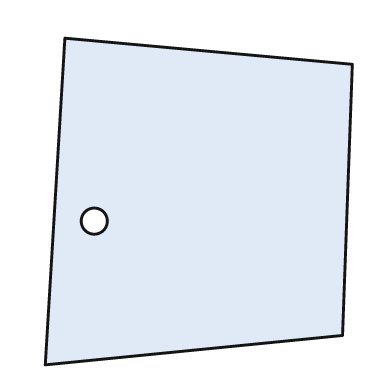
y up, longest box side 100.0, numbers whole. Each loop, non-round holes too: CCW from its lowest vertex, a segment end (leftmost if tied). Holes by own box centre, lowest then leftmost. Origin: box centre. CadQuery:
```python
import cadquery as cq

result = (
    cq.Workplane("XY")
    .moveTo(-47.0, -50.0)
    .lineTo(44.0, -41.0)
    .lineTo(47.0, 42.0)
    .lineTo(-41.0, 50.0)
    .close()
    .moveTo(-32.0, -6.0)
    .circle(4.0)
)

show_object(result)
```